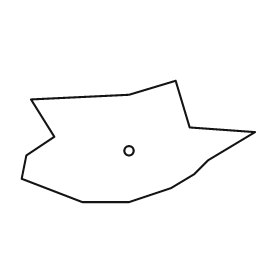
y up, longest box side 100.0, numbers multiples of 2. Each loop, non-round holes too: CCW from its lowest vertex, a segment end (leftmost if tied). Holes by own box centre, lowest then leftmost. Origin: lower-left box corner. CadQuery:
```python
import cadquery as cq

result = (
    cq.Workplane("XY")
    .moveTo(26.0, 0.0)
    .lineTo(46.0, 0.0)
    .lineTo(64.0, 6.0)
    .lineTo(74.0, 12.0)
    .lineTo(80.0, 18.0)
    .lineTo(100.0, 30.0)
    .lineTo(72.0, 32.0)
    .lineTo(66.0, 52.0)
    .lineTo(46.0, 46.0)
    .lineTo(4.0, 44.0)
    .lineTo(14.0, 28.0)
    .lineTo(2.0, 20.0)
    .lineTo(0.0, 10.0)
    .close()
    .moveTo(46.0, 22.0)
    .circle(2.0)
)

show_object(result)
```